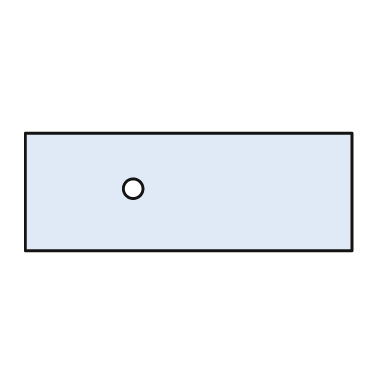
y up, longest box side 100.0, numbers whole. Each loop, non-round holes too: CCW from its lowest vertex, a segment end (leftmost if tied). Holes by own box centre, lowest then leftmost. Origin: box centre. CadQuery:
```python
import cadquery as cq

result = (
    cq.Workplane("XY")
    .moveTo(-50.0, -18.0)
    .lineTo(50.0, -18.0)
    .lineTo(50.0, 18.0)
    .lineTo(-50.0, 18.0)
    .close()
    .moveTo(-17.0, 1.0)
    .circle(3.0)
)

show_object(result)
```